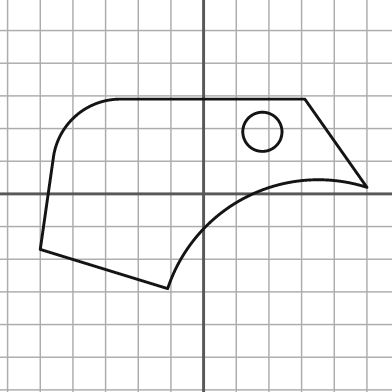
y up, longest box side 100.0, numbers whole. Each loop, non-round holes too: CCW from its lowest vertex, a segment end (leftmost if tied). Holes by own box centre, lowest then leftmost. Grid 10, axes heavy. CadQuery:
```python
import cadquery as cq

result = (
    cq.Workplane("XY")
    .moveTo(-11.0, -29.0)
    .threePointArc((13.0, -1.0), (50.0, 2.0))
    .lineTo(31.0, 29.0)
    .lineTo(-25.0, 29.0)
    .threePointArc((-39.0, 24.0), (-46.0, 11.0))
    .lineTo(-50.0, -17.0)
    .close()
    .moveTo(18.0, 19.0)
    .circle(6.0)
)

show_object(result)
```